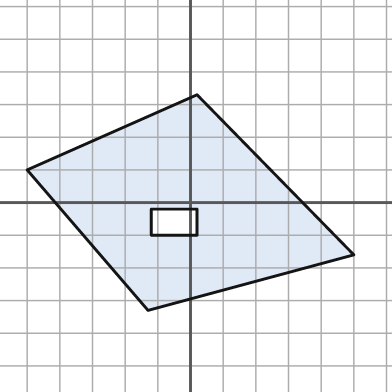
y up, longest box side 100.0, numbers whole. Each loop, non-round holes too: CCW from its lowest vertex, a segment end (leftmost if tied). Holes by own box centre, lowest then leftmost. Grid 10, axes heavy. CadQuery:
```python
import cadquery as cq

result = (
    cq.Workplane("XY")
    .moveTo(-13.0, -33.0)
    .lineTo(50.0, -16.0)
    .lineTo(2.0, 33.0)
    .lineTo(-50.0, 10.0)
    .close()
    .moveTo(-12.0, -10.0)
    .lineTo(2.0, -10.0)
    .lineTo(2.0, -2.0)
    .lineTo(-12.0, -2.0)
    .close()
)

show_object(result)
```